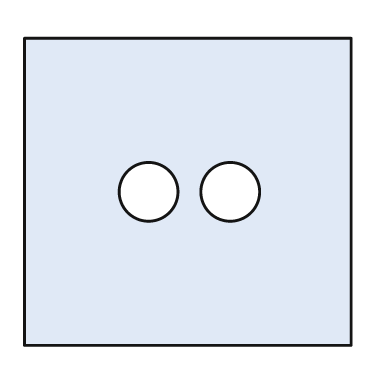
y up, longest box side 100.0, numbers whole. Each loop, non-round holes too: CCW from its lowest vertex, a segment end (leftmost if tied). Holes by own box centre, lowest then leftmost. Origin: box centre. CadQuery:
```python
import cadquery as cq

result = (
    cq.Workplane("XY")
    .moveTo(-50.0, -47.0)
    .lineTo(50.0, -47.0)
    .lineTo(50.0, 47.0)
    .lineTo(-50.0, 47.0)
    .close()
    .moveTo(-12.0, 0.0)
    .circle(9.0)
    .moveTo(13.0, 0.0)
    .circle(9.0)
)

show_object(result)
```